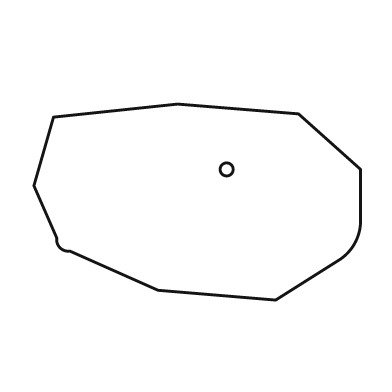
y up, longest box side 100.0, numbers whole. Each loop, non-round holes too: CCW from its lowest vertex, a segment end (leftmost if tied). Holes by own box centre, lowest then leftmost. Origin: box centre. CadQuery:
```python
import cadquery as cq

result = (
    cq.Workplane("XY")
    .moveTo(24.0, -30.0)
    .lineTo(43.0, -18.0)
    .threePointArc((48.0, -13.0), (50.0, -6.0))
    .lineTo(50.0, 10.0)
    .lineTo(31.0, 27.0)
    .lineTo(-6.0, 30.0)
    .lineTo(-44.0, 26.0)
    .lineTo(-50.0, 5.0)
    .lineTo(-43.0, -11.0)
    .threePointArc((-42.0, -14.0), (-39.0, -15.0))
    .lineTo(-12.0, -27.0)
    .close()
    .moveTo(9.0, 10.0)
    .circle(2.0)
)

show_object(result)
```